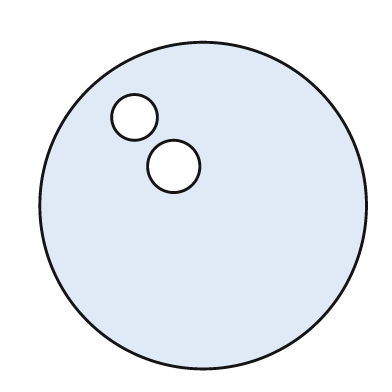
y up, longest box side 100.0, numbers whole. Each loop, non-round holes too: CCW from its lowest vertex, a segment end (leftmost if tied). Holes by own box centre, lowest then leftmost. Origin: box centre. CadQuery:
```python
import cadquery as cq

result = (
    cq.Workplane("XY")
    .moveTo(0.0, 0.0)
    .circle(50.0)
    .moveTo(-9.0, 12.0)
    .circle(8.0)
    .moveTo(-21.0, 27.0)
    .circle(7.0)
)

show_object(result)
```